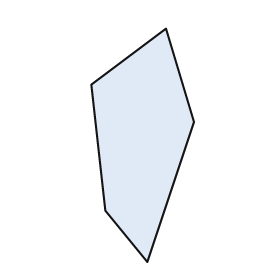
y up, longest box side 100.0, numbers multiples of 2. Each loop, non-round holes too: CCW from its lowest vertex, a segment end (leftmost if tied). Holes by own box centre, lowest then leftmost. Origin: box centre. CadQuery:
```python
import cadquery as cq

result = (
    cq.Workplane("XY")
    .moveTo(2.0, -50.0)
    .lineTo(22.0, 10.0)
    .lineTo(10.0, 50.0)
    .lineTo(-22.0, 26.0)
    .lineTo(-16.0, -28.0)
    .close()
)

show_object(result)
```